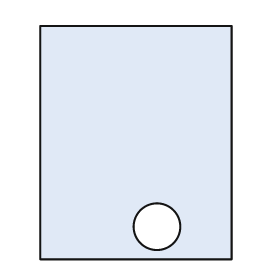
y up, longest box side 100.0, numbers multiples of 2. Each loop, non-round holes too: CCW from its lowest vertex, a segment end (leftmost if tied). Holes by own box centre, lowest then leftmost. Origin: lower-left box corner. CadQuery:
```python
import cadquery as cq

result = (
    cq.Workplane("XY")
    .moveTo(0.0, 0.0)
    .lineTo(82.0, 0.0)
    .lineTo(82.0, 100.0)
    .lineTo(0.0, 100.0)
    .close()
    .moveTo(50.0, 14.0)
    .circle(10.0)
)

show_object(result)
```